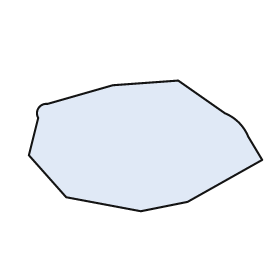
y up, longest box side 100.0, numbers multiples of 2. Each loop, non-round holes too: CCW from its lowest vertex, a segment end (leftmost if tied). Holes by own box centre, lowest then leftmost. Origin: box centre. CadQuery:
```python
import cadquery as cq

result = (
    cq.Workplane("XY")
    .moveTo(-2.0, -28.0)
    .lineTo(18.0, -24.0)
    .lineTo(50.0, -6.0)
    .lineTo(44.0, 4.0)
    .threePointArc((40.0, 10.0), (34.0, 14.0))
    .lineTo(14.0, 28.0)
    .lineTo(-14.0, 26.0)
    .lineTo(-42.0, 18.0)
    .threePointArc((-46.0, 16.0), (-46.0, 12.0))
    .lineTo(-50.0, -4.0)
    .lineTo(-34.0, -22.0)
    .close()
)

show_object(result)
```